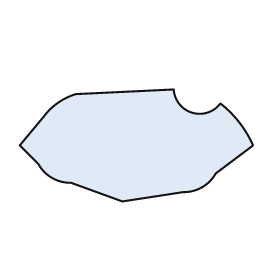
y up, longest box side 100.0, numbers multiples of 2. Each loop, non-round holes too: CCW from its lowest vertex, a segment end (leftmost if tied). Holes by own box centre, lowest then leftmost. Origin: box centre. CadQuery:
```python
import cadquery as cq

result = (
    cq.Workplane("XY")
    .moveTo(-6.0, -24.0)
    .lineTo(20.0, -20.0)
    .threePointArc((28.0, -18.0), (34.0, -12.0))
    .lineTo(50.0, 0.0)
    .threePointArc((44.0, 10.0), (36.0, 18.0))
    .threePointArc((24.0, 14.0), (16.0, 24.0))
    .lineTo(-26.0, 22.0)
    .threePointArc((-34.0, 18.0), (-40.0, 12.0))
    .lineTo(-50.0, 0.0)
    .lineTo(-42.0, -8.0)
    .threePointArc((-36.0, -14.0), (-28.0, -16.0))
    .close()
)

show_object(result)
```